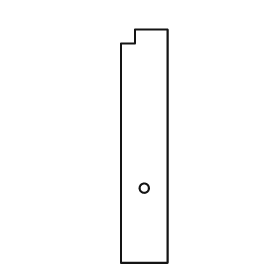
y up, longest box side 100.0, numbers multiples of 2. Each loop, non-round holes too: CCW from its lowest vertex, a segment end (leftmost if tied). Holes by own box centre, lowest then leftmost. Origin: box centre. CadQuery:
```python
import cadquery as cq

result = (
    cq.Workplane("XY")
    .moveTo(-10.0, -50.0)
    .lineTo(10.0, -50.0)
    .lineTo(10.0, 50.0)
    .lineTo(-4.0, 50.0)
    .lineTo(-4.0, 44.0)
    .lineTo(-10.0, 44.0)
    .close()
    .moveTo(0.0, -18.0)
    .circle(2.0)
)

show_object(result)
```